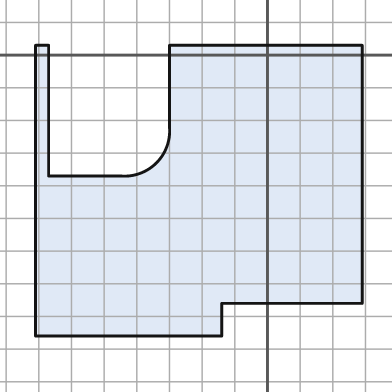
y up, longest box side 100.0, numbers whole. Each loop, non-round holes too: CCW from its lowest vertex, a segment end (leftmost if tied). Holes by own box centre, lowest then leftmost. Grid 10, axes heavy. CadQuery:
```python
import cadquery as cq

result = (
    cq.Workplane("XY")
    .moveTo(-71.0, -86.0)
    .lineTo(-14.0, -86.0)
    .lineTo(-14.0, -76.0)
    .lineTo(29.0, -76.0)
    .lineTo(29.0, 3.0)
    .lineTo(-30.0, 3.0)
    .lineTo(-30.0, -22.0)
    .threePointArc((-34.0, -33.0), (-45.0, -37.0))
    .lineTo(-67.0, -37.0)
    .lineTo(-67.0, 3.0)
    .lineTo(-71.0, 3.0)
    .close()
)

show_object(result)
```